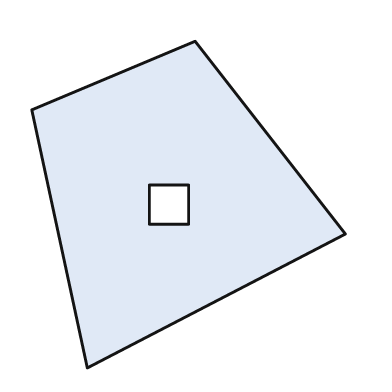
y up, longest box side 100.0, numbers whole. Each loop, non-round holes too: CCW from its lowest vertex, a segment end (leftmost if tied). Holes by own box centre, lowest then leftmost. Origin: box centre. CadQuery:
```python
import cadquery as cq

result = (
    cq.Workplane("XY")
    .moveTo(-31.0, -50.0)
    .lineTo(48.0, -9.0)
    .lineTo(2.0, 50.0)
    .lineTo(-48.0, 29.0)
    .close()
    .moveTo(-12.0, -6.0)
    .lineTo(0.0, -6.0)
    .lineTo(0.0, 6.0)
    .lineTo(-12.0, 6.0)
    .close()
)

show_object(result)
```